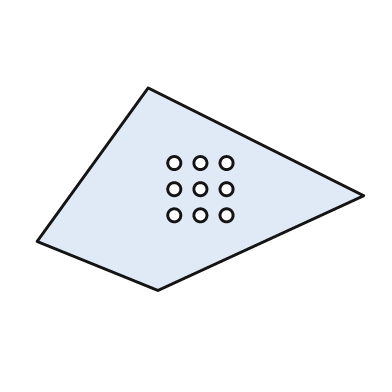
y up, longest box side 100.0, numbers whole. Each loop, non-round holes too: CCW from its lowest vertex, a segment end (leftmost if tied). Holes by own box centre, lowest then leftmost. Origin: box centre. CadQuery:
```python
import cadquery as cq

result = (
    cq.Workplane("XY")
    .moveTo(-13.0, -31.0)
    .lineTo(50.0, -2.0)
    .lineTo(-16.0, 31.0)
    .lineTo(-50.0, -16.0)
    .close()
    .moveTo(-8.0, -8.0)
    .circle(2.0)
    .moveTo(0.0, -8.0)
    .circle(2.0)
    .moveTo(8.0, -8.0)
    .circle(2.0)
    .moveTo(-8.0, 0.0)
    .circle(2.0)
    .moveTo(0.0, 0.0)
    .circle(2.0)
    .moveTo(8.0, 0.0)
    .circle(2.0)
    .moveTo(-8.0, 8.0)
    .circle(2.0)
    .moveTo(0.0, 8.0)
    .circle(2.0)
    .moveTo(8.0, 8.0)
    .circle(2.0)
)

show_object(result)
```